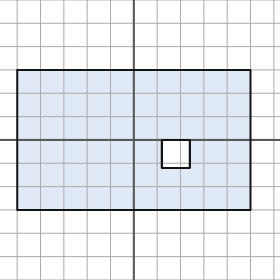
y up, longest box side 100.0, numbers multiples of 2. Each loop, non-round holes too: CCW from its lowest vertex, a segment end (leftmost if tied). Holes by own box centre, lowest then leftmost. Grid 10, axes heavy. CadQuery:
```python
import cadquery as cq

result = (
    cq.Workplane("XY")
    .moveTo(-50.0, -30.0)
    .lineTo(50.0, -30.0)
    .lineTo(50.0, 30.0)
    .lineTo(-50.0, 30.0)
    .close()
    .moveTo(12.0, -12.0)
    .lineTo(24.0, -12.0)
    .lineTo(24.0, 0.0)
    .lineTo(12.0, 0.0)
    .close()
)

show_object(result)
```